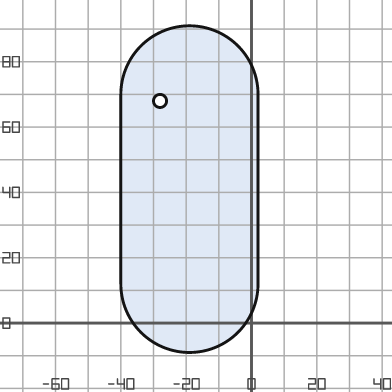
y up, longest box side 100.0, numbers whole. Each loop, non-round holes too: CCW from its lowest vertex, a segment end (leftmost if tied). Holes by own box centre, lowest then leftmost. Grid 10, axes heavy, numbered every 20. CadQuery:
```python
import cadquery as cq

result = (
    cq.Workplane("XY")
    .moveTo(-40.0, 12.0)
    .threePointArc((-19.0, -9.0), (2.0, 12.0))
    .lineTo(2.0, 70.0)
    .threePointArc((-19.0, 91.0), (-40.0, 70.0))
    .close()
    .moveTo(-28.0, 68.0)
    .circle(2.0)
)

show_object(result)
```